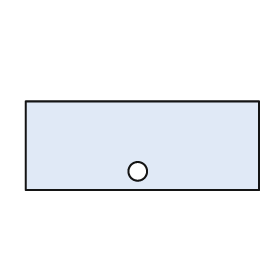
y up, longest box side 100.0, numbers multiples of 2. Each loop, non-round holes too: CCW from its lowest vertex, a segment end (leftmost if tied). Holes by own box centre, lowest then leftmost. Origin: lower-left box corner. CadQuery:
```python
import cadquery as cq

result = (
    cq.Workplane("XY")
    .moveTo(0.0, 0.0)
    .lineTo(100.0, 0.0)
    .lineTo(100.0, 38.0)
    .lineTo(0.0, 38.0)
    .close()
    .moveTo(48.0, 8.0)
    .circle(4.0)
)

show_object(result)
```